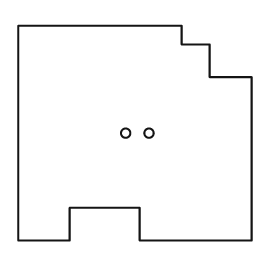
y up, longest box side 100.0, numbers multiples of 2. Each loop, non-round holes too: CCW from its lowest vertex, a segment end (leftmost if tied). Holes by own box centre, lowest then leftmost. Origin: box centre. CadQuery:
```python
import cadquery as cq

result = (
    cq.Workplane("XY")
    .moveTo(-50.0, -46.0)
    .lineTo(-28.0, -46.0)
    .lineTo(-28.0, -32.0)
    .lineTo(2.0, -32.0)
    .lineTo(2.0, -46.0)
    .lineTo(50.0, -46.0)
    .lineTo(50.0, 24.0)
    .lineTo(32.0, 24.0)
    .lineTo(32.0, 38.0)
    .lineTo(20.0, 38.0)
    .lineTo(20.0, 46.0)
    .lineTo(-50.0, 46.0)
    .close()
    .moveTo(-4.0, 0.0)
    .circle(2.0)
    .moveTo(6.0, 0.0)
    .circle(2.0)
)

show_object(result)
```